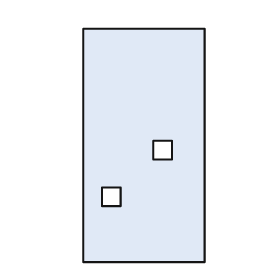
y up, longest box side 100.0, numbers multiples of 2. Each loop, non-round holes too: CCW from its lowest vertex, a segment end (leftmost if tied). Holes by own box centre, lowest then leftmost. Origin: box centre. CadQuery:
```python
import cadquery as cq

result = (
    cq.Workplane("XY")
    .moveTo(-26.0, -50.0)
    .lineTo(26.0, -50.0)
    .lineTo(26.0, 50.0)
    .lineTo(-26.0, 50.0)
    .close()
    .moveTo(-18.0, -26.0)
    .lineTo(-10.0, -26.0)
    .lineTo(-10.0, -18.0)
    .lineTo(-18.0, -18.0)
    .close()
    .moveTo(4.0, -6.0)
    .lineTo(12.0, -6.0)
    .lineTo(12.0, 2.0)
    .lineTo(4.0, 2.0)
    .close()
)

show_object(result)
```